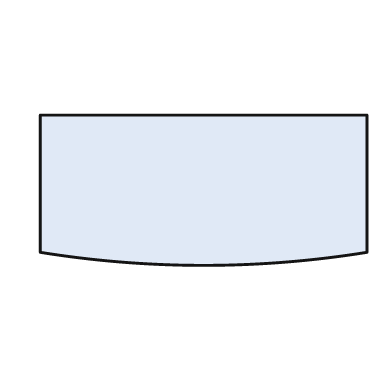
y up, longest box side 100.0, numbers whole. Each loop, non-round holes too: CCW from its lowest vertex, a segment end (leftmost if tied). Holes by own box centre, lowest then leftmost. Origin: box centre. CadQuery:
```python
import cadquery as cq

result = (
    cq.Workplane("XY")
    .moveTo(-50.0, -19.0)
    .threePointArc((0.0, -23.0), (50.0, -19.0))
    .lineTo(50.0, 23.0)
    .lineTo(-50.0, 23.0)
    .close()
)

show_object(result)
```